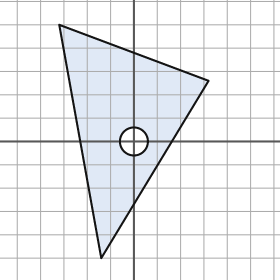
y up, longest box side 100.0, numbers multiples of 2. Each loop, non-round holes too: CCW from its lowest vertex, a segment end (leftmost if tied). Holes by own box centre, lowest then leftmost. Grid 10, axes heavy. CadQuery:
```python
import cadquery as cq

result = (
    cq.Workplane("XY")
    .moveTo(-14.0, -50.0)
    .lineTo(32.0, 26.0)
    .lineTo(-32.0, 50.0)
    .close()
    .moveTo(0.0, 0.0)
    .circle(6.0)
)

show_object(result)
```